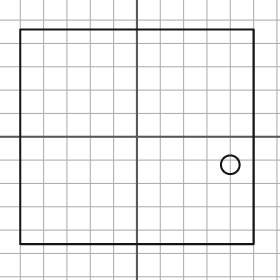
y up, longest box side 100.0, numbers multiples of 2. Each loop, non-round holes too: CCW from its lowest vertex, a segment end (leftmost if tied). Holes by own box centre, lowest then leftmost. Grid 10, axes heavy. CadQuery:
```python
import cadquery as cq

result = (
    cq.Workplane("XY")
    .moveTo(-50.0, -46.0)
    .lineTo(50.0, -46.0)
    .lineTo(50.0, 46.0)
    .lineTo(-50.0, 46.0)
    .close()
    .moveTo(40.0, -12.0)
    .circle(4.0)
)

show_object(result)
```